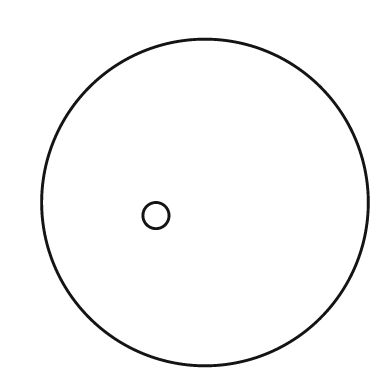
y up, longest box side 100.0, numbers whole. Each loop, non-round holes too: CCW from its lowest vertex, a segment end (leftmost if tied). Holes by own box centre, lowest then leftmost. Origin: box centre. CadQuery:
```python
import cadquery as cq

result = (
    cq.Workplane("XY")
    .moveTo(0.0, 0.0)
    .circle(50.0)
    .moveTo(-15.0, -4.0)
    .circle(4.0)
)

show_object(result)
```